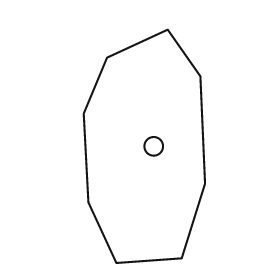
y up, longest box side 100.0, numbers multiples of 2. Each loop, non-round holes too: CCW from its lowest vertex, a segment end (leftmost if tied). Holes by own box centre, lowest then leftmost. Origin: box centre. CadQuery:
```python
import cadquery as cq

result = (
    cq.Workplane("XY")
    .moveTo(-12.0, -50.0)
    .lineTo(16.0, -48.0)
    .lineTo(26.0, -16.0)
    .lineTo(24.0, 30.0)
    .lineTo(10.0, 50.0)
    .lineTo(-16.0, 38.0)
    .lineTo(-26.0, 14.0)
    .lineTo(-24.0, -24.0)
    .close()
    .moveTo(4.0, 0.0)
    .circle(4.0)
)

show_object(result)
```